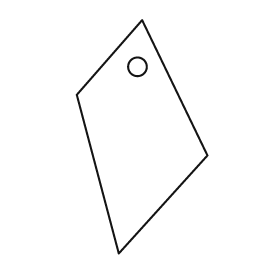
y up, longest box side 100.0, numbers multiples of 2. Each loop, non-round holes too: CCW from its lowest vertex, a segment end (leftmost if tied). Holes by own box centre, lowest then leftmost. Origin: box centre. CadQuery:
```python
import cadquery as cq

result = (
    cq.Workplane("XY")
    .moveTo(-10.0, -50.0)
    .lineTo(28.0, -8.0)
    .lineTo(0.0, 50.0)
    .lineTo(-28.0, 18.0)
    .close()
    .moveTo(-2.0, 30.0)
    .circle(4.0)
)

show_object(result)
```